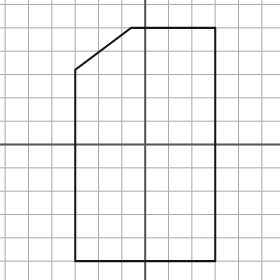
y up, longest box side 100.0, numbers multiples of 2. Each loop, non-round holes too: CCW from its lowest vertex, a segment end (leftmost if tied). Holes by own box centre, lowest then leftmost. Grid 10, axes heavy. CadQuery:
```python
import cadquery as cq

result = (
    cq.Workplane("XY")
    .moveTo(-30.0, -50.0)
    .lineTo(30.0, -50.0)
    .lineTo(30.0, 50.0)
    .lineTo(-6.0, 50.0)
    .lineTo(-30.0, 32.0)
    .close()
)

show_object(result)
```